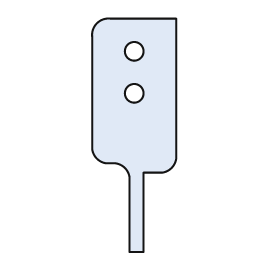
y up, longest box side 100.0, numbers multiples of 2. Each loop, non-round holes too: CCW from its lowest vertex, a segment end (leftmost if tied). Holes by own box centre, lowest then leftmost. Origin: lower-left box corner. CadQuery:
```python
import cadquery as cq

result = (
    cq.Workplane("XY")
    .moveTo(16.0, 0.0)
    .lineTo(22.0, 0.0)
    .lineTo(22.0, 34.0)
    .lineTo(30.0, 34.0)
    .threePointArc((34.0, 36.0), (36.0, 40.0))
    .lineTo(36.0, 100.0)
    .lineTo(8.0, 100.0)
    .threePointArc((2.0, 98.0), (0.0, 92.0))
    .lineTo(0.0, 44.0)
    .threePointArc((2.0, 40.0), (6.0, 38.0))
    .lineTo(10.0, 38.0)
    .threePointArc((14.0, 36.0), (16.0, 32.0))
    .close()
    .moveTo(18.0, 68.0)
    .circle(4.0)
    .moveTo(18.0, 86.0)
    .circle(4.0)
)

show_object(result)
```